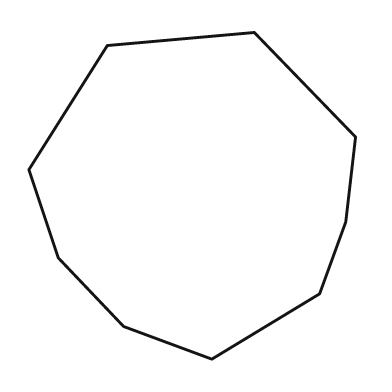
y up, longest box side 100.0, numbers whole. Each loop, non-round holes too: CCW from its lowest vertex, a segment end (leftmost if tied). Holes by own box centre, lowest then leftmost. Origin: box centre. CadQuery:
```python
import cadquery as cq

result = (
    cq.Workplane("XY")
    .moveTo(6.0, -50.0)
    .lineTo(39.0, -30.0)
    .lineTo(47.0, -8.0)
    .lineTo(50.0, 18.0)
    .lineTo(19.0, 50.0)
    .lineTo(-26.0, 46.0)
    .lineTo(-50.0, 8.0)
    .lineTo(-41.0, -19.0)
    .lineTo(-21.0, -40.0)
    .close()
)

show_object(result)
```